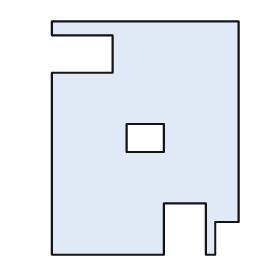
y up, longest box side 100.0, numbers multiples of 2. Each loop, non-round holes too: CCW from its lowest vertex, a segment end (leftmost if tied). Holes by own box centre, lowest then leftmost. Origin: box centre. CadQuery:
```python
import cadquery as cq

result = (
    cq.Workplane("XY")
    .moveTo(-40.0, -50.0)
    .lineTo(8.0, -50.0)
    .lineTo(8.0, -28.0)
    .lineTo(26.0, -28.0)
    .lineTo(26.0, -50.0)
    .lineTo(30.0, -50.0)
    .lineTo(30.0, -36.0)
    .lineTo(40.0, -36.0)
    .lineTo(40.0, 50.0)
    .lineTo(-40.0, 50.0)
    .lineTo(-40.0, 44.0)
    .lineTo(-14.0, 44.0)
    .lineTo(-14.0, 28.0)
    .lineTo(-40.0, 28.0)
    .close()
    .moveTo(-8.0, -6.0)
    .lineTo(8.0, -6.0)
    .lineTo(8.0, 6.0)
    .lineTo(-8.0, 6.0)
    .close()
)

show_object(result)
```